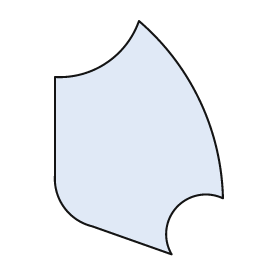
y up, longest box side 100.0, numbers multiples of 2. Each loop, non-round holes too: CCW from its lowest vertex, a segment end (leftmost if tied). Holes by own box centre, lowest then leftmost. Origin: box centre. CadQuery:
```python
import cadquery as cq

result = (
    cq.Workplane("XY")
    .moveTo(14.0, -50.0)
    .threePointArc((16.0, -30.0), (36.0, -26.0))
    .threePointArc((26.0, 16.0), (0.0, 50.0))
    .threePointArc((-14.0, 32.0), (-36.0, 26.0))
    .lineTo(-36.0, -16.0)
    .threePointArc((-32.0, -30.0), (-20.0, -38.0))
    .close()
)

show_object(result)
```